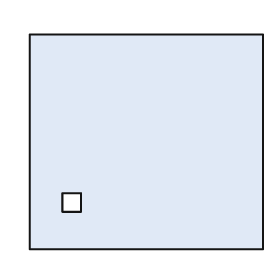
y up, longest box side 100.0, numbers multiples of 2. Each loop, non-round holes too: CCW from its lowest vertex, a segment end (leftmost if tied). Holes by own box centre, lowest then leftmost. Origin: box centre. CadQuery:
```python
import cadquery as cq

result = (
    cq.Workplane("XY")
    .moveTo(-50.0, -46.0)
    .lineTo(50.0, -46.0)
    .lineTo(50.0, 46.0)
    .lineTo(-50.0, 46.0)
    .close()
    .moveTo(-36.0, -30.0)
    .lineTo(-28.0, -30.0)
    .lineTo(-28.0, -22.0)
    .lineTo(-36.0, -22.0)
    .close()
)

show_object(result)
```